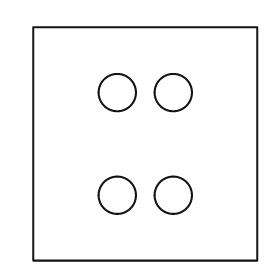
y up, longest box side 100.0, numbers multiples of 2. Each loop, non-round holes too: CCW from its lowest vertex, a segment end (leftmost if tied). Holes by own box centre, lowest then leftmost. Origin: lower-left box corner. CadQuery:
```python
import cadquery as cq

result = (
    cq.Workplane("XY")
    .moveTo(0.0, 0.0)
    .lineTo(96.0, 0.0)
    .lineTo(96.0, 100.0)
    .lineTo(0.0, 100.0)
    .close()
    .moveTo(36.0, 28.0)
    .circle(8.0)
    .moveTo(60.0, 28.0)
    .circle(8.0)
    .moveTo(36.0, 72.0)
    .circle(8.0)
    .moveTo(60.0, 72.0)
    .circle(8.0)
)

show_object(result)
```